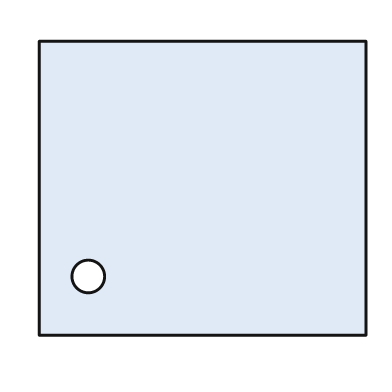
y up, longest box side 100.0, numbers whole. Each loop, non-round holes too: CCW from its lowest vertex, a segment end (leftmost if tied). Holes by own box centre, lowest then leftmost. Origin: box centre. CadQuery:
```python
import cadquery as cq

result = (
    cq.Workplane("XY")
    .moveTo(-50.0, -45.0)
    .lineTo(50.0, -45.0)
    .lineTo(50.0, 45.0)
    .lineTo(-50.0, 45.0)
    .close()
    .moveTo(-35.0, -27.0)
    .circle(5.0)
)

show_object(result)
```